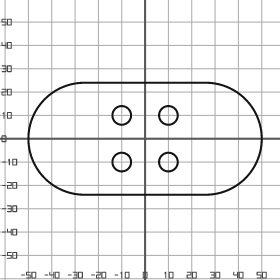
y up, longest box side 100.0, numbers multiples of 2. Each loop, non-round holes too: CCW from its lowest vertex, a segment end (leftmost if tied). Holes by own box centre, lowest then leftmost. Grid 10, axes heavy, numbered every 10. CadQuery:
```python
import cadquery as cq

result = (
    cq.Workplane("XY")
    .moveTo(-26.0, -24.0)
    .lineTo(26.0, -24.0)
    .threePointArc((50.0, 0.0), (26.0, 24.0))
    .lineTo(-26.0, 24.0)
    .threePointArc((-50.0, 0.0), (-26.0, -24.0))
    .close()
    .moveTo(-10.0, -10.0)
    .circle(4.0)
    .moveTo(10.0, -10.0)
    .circle(4.0)
    .moveTo(-10.0, 10.0)
    .circle(4.0)
    .moveTo(10.0, 10.0)
    .circle(4.0)
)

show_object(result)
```